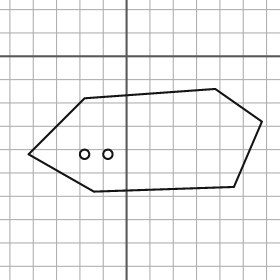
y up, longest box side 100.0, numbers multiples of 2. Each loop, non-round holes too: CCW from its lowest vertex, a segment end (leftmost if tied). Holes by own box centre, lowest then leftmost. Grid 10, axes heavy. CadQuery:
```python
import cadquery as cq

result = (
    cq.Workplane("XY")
    .moveTo(-14.0, -58.0)
    .lineTo(46.0, -56.0)
    .lineTo(58.0, -28.0)
    .lineTo(38.0, -14.0)
    .lineTo(-18.0, -18.0)
    .lineTo(-42.0, -42.0)
    .close()
    .moveTo(-18.0, -42.0)
    .circle(2.0)
    .moveTo(-8.0, -42.0)
    .circle(2.0)
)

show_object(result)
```